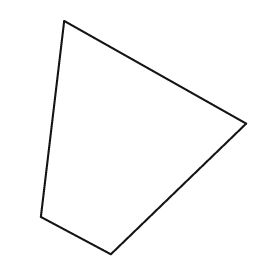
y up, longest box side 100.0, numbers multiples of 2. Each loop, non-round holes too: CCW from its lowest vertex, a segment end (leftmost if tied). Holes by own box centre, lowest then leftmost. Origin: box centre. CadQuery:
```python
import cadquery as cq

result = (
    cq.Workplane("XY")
    .moveTo(-14.0, -50.0)
    .lineTo(44.0, 6.0)
    .lineTo(-34.0, 50.0)
    .lineTo(-44.0, -34.0)
    .close()
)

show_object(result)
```